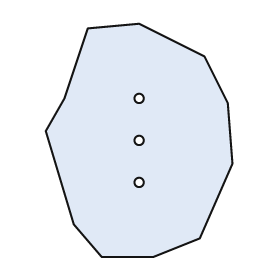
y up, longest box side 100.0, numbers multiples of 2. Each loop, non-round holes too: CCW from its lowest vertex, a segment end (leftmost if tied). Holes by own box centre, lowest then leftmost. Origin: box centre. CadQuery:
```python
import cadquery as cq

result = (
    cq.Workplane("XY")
    .moveTo(-16.0, -50.0)
    .lineTo(6.0, -50.0)
    .lineTo(26.0, -42.0)
    .lineTo(40.0, -10.0)
    .lineTo(38.0, 16.0)
    .lineTo(28.0, 36.0)
    .lineTo(0.0, 50.0)
    .lineTo(-22.0, 48.0)
    .lineTo(-32.0, 18.0)
    .lineTo(-40.0, 4.0)
    .lineTo(-28.0, -36.0)
    .close()
    .moveTo(0.0, -18.0)
    .circle(2.0)
    .moveTo(0.0, 0.0)
    .circle(2.0)
    .moveTo(0.0, 18.0)
    .circle(2.0)
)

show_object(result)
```